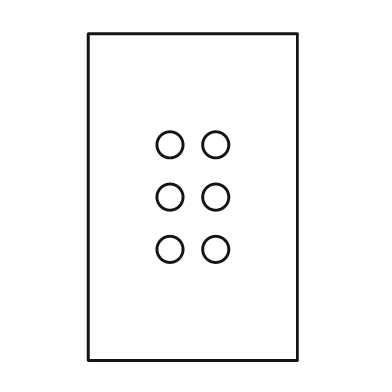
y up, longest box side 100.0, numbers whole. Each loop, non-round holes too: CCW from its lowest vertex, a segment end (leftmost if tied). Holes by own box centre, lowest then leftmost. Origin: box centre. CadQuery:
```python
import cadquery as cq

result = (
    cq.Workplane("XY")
    .moveTo(-32.0, -50.0)
    .lineTo(32.0, -50.0)
    .lineTo(32.0, 50.0)
    .lineTo(-32.0, 50.0)
    .close()
    .moveTo(-7.0, -16.0)
    .circle(4.0)
    .moveTo(7.0, -16.0)
    .circle(4.0)
    .moveTo(-7.0, 0.0)
    .circle(4.0)
    .moveTo(7.0, 0.0)
    .circle(4.0)
    .moveTo(-7.0, 16.0)
    .circle(4.0)
    .moveTo(7.0, 16.0)
    .circle(4.0)
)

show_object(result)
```